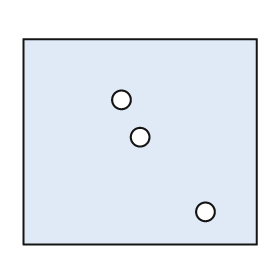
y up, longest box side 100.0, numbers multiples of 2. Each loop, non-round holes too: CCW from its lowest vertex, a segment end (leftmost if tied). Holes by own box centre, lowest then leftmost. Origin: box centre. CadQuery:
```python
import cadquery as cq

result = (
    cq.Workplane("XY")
    .moveTo(-50.0, -44.0)
    .lineTo(50.0, -44.0)
    .lineTo(50.0, 44.0)
    .lineTo(-50.0, 44.0)
    .close()
    .moveTo(28.0, -30.0)
    .circle(4.0)
    .moveTo(0.0, 2.0)
    .circle(4.0)
    .moveTo(-8.0, 18.0)
    .circle(4.0)
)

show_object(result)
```